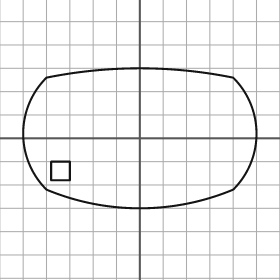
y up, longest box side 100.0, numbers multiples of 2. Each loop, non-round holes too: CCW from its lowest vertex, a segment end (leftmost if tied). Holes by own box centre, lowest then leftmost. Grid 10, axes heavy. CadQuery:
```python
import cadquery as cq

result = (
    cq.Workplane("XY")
    .moveTo(-40.0, -22.0)
    .threePointArc((0.0, -30.0), (40.0, -22.0))
    .threePointArc((50.0, 2.0), (40.0, 26.0))
    .threePointArc((0.0, 30.0), (-40.0, 26.0))
    .threePointArc((-50.0, 2.0), (-40.0, -22.0))
    .close()
    .moveTo(-38.0, -18.0)
    .lineTo(-30.0, -18.0)
    .lineTo(-30.0, -10.0)
    .lineTo(-38.0, -10.0)
    .close()
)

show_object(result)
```